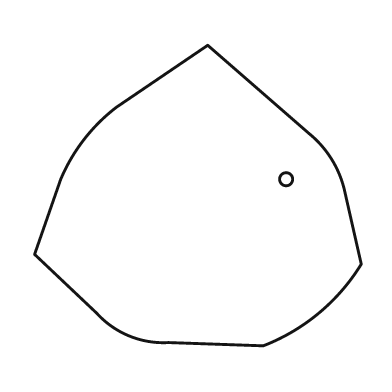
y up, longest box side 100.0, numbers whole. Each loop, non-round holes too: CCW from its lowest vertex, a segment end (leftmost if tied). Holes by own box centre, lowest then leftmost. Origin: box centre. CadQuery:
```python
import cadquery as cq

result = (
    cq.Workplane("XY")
    .moveTo(20.0, -46.0)
    .threePointArc((37.0, -36.0), (50.0, -21.0))
    .lineTo(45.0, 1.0)
    .threePointArc((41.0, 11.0), (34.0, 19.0))
    .lineTo(3.0, 46.0)
    .lineTo(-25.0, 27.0)
    .threePointArc((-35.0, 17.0), (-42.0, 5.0))
    .lineTo(-50.0, -18.0)
    .lineTo(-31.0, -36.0)
    .threePointArc((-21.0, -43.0), (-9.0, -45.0))
    .close()
    .moveTo(27.0, 5.0)
    .circle(2.0)
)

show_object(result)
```